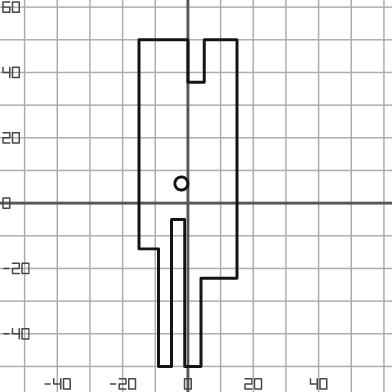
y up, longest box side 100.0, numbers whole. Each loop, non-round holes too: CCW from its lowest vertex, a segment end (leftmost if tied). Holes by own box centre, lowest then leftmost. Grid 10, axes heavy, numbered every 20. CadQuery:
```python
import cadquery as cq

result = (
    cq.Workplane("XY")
    .moveTo(-9.0, -50.0)
    .lineTo(-5.0, -50.0)
    .lineTo(-5.0, -5.0)
    .lineTo(-1.0, -5.0)
    .lineTo(-1.0, -50.0)
    .lineTo(4.0, -50.0)
    .lineTo(4.0, -23.0)
    .lineTo(15.0, -23.0)
    .lineTo(15.0, 50.0)
    .lineTo(5.0, 50.0)
    .lineTo(5.0, 37.0)
    .lineTo(0.0, 37.0)
    .lineTo(0.0, 50.0)
    .lineTo(-15.0, 50.0)
    .lineTo(-15.0, -14.0)
    .lineTo(-9.0, -14.0)
    .close()
    .moveTo(-2.0, 6.0)
    .circle(2.0)
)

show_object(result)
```